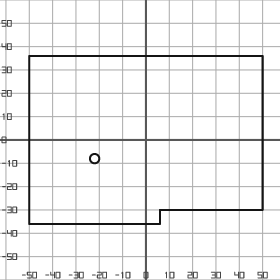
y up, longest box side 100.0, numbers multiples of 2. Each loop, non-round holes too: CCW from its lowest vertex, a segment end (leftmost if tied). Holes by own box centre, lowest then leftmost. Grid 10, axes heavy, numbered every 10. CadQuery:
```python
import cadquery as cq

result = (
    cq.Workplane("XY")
    .moveTo(-50.0, -36.0)
    .lineTo(6.0, -36.0)
    .lineTo(6.0, -30.0)
    .lineTo(50.0, -30.0)
    .lineTo(50.0, 36.0)
    .lineTo(-50.0, 36.0)
    .close()
    .moveTo(-22.0, -8.0)
    .circle(2.0)
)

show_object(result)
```